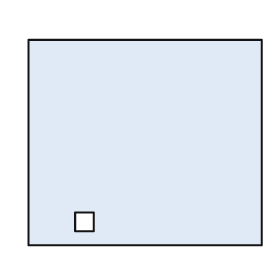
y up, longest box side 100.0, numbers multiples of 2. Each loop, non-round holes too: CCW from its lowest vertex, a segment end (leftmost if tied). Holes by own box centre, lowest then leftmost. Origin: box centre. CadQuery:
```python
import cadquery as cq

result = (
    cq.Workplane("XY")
    .moveTo(-50.0, -44.0)
    .lineTo(50.0, -44.0)
    .lineTo(50.0, 44.0)
    .lineTo(-50.0, 44.0)
    .close()
    .moveTo(-30.0, -38.0)
    .lineTo(-22.0, -38.0)
    .lineTo(-22.0, -30.0)
    .lineTo(-30.0, -30.0)
    .close()
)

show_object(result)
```